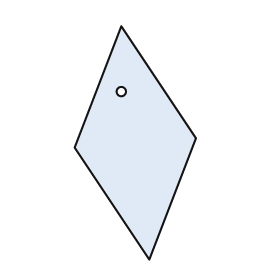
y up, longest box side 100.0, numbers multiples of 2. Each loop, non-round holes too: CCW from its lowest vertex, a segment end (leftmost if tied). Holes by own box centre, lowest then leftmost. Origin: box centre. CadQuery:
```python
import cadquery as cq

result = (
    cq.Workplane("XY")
    .moveTo(6.0, -50.0)
    .lineTo(26.0, 2.0)
    .lineTo(-6.0, 50.0)
    .lineTo(-26.0, -2.0)
    .close()
    .moveTo(-6.0, 22.0)
    .circle(2.0)
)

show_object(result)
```